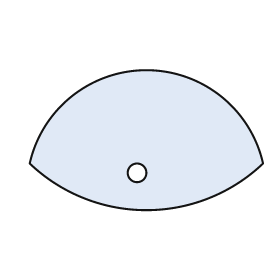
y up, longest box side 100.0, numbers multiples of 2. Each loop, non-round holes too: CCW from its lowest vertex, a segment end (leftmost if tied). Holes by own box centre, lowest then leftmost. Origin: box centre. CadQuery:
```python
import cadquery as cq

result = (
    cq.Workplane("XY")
    .moveTo(-50.0, -10.0)
    .threePointArc((0.0, -30.0), (50.0, -10.0))
    .threePointArc((0.0, 30.0), (-50.0, -10.0))
    .close()
    .moveTo(-4.0, -14.0)
    .circle(4.0)
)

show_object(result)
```